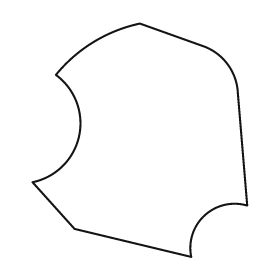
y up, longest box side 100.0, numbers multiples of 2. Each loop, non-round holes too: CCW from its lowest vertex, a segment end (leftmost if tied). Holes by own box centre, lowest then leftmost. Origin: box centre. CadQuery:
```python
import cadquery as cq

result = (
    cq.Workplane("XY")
    .moveTo(22.0, -50.0)
    .threePointArc((28.0, -32.0), (46.0, -28.0))
    .lineTo(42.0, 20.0)
    .threePointArc((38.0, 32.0), (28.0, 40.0))
    .lineTo(0.0, 50.0)
    .threePointArc((-20.0, 42.0), (-36.0, 28.0))
    .threePointArc((-26.0, 2.0), (-46.0, -18.0))
    .lineTo(-28.0, -38.0)
    .close()
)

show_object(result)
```